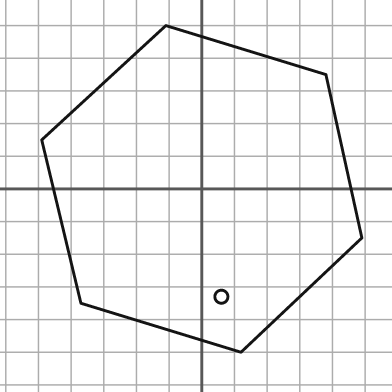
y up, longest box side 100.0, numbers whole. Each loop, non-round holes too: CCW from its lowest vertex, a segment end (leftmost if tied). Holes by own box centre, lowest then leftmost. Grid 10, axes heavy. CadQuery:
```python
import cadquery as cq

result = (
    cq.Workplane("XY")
    .moveTo(12.0, -50.0)
    .lineTo(49.0, -15.0)
    .lineTo(38.0, 35.0)
    .lineTo(-11.0, 50.0)
    .lineTo(-49.0, 15.0)
    .lineTo(-37.0, -35.0)
    .close()
    .moveTo(6.0, -33.0)
    .circle(2.0)
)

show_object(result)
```